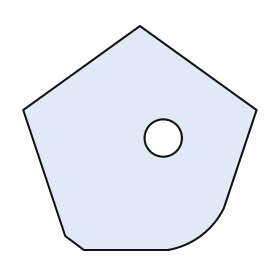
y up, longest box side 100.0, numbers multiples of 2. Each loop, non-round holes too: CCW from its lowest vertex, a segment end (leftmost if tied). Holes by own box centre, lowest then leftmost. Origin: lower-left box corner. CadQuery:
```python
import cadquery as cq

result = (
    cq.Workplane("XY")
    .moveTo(26.0, 0.0)
    .lineTo(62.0, 0.0)
    .threePointArc((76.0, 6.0), (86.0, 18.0))
    .lineTo(100.0, 60.0)
    .lineTo(50.0, 96.0)
    .lineTo(0.0, 60.0)
    .lineTo(18.0, 6.0)
    .close()
    .moveTo(60.0, 48.0)
    .circle(8.0)
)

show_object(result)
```